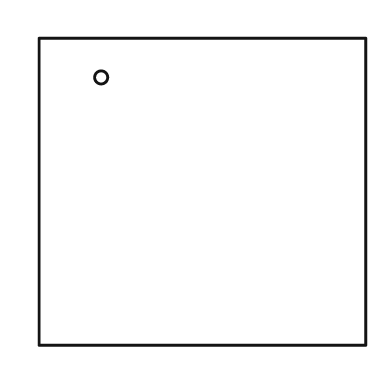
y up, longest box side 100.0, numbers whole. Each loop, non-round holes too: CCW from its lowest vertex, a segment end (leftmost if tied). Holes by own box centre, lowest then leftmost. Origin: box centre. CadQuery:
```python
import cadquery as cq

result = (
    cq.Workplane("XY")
    .moveTo(-50.0, -47.0)
    .lineTo(50.0, -47.0)
    .lineTo(50.0, 47.0)
    .lineTo(-50.0, 47.0)
    .close()
    .moveTo(-31.0, 35.0)
    .circle(2.0)
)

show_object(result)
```